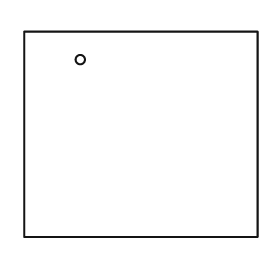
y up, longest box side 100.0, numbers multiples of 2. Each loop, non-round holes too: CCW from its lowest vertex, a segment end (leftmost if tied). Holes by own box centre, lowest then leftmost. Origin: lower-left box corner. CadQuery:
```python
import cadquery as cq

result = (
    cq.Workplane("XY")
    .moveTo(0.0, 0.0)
    .lineTo(100.0, 0.0)
    .lineTo(100.0, 88.0)
    .lineTo(0.0, 88.0)
    .close()
    .moveTo(24.0, 76.0)
    .circle(2.0)
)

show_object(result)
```